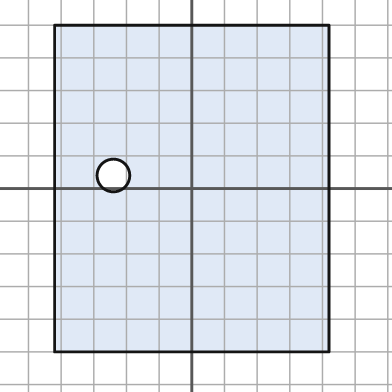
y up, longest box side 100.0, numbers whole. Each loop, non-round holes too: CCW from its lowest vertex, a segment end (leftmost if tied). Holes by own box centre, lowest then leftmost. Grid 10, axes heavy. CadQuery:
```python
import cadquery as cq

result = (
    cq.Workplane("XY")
    .moveTo(-42.0, -50.0)
    .lineTo(42.0, -50.0)
    .lineTo(42.0, 50.0)
    .lineTo(-42.0, 50.0)
    .close()
    .moveTo(-24.0, 4.0)
    .circle(5.0)
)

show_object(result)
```